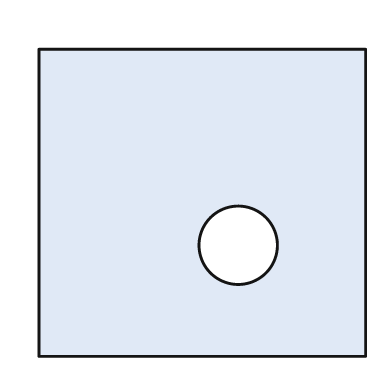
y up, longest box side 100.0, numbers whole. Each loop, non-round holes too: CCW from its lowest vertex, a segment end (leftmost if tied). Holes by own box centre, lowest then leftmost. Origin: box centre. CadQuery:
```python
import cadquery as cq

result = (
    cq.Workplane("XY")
    .moveTo(-50.0, -47.0)
    .lineTo(50.0, -47.0)
    .lineTo(50.0, 47.0)
    .lineTo(-50.0, 47.0)
    .close()
    .moveTo(11.0, -13.0)
    .circle(12.0)
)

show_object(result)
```